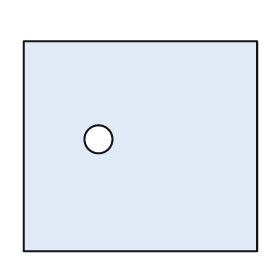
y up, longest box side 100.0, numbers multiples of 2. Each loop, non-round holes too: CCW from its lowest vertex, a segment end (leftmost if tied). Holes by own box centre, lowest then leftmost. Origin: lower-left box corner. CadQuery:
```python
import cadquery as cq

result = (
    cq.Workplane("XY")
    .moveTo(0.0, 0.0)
    .lineTo(100.0, 0.0)
    .lineTo(100.0, 90.0)
    .lineTo(0.0, 90.0)
    .close()
    .moveTo(32.0, 48.0)
    .circle(6.0)
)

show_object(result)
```